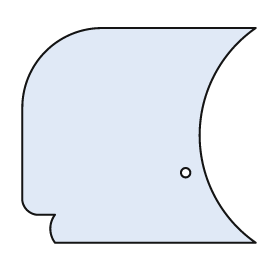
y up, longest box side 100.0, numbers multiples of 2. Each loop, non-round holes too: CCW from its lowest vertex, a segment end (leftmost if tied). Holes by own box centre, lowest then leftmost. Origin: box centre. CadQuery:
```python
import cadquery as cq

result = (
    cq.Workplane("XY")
    .moveTo(-36.0, -46.0)
    .lineTo(50.0, -46.0)
    .threePointArc((26.0, 0.0), (50.0, 46.0))
    .lineTo(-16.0, 46.0)
    .threePointArc((-40.0, 36.0), (-50.0, 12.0))
    .lineTo(-50.0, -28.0)
    .threePointArc((-48.0, -32.0), (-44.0, -34.0))
    .lineTo(-36.0, -34.0)
    .threePointArc((-38.0, -40.0), (-36.0, -46.0))
    .close()
    .moveTo(20.0, -16.0)
    .circle(2.0)
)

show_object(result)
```